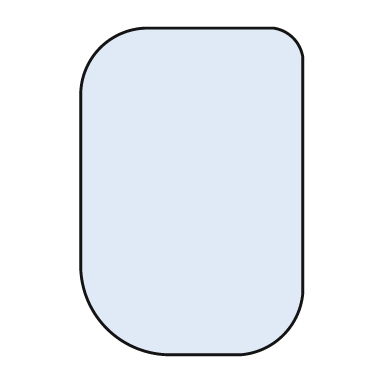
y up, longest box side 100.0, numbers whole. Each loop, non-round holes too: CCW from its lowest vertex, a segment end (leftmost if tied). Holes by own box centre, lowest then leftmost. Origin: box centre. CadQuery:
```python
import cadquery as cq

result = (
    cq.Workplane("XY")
    .moveTo(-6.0, -50.0)
    .lineTo(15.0, -50.0)
    .threePointArc((28.0, -44.0), (34.0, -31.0))
    .lineTo(34.0, 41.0)
    .threePointArc((31.0, 47.0), (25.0, 50.0))
    .lineTo(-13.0, 50.0)
    .threePointArc((-28.0, 44.0), (-34.0, 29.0))
    .lineTo(-34.0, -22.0)
    .threePointArc((-26.0, -42.0), (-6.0, -50.0))
    .close()
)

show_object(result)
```